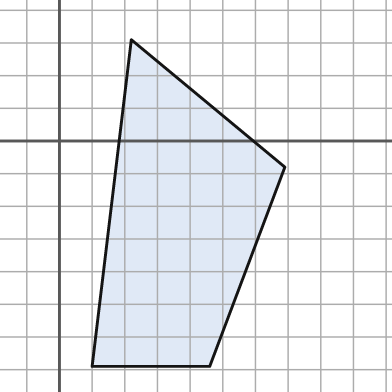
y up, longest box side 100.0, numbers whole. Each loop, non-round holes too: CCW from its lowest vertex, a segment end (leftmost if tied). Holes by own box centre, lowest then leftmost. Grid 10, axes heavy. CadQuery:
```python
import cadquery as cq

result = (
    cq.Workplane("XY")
    .moveTo(10.0, -69.0)
    .lineTo(46.0, -69.0)
    .lineTo(69.0, -8.0)
    .lineTo(22.0, 31.0)
    .close()
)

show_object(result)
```